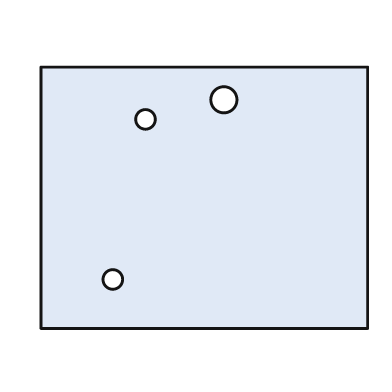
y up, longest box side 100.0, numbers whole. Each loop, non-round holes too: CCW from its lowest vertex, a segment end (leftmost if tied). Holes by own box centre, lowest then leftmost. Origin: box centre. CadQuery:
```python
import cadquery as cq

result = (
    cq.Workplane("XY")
    .moveTo(-50.0, -40.0)
    .lineTo(50.0, -40.0)
    .lineTo(50.0, 40.0)
    .lineTo(-50.0, 40.0)
    .close()
    .moveTo(-28.0, -25.0)
    .circle(3.0)
    .moveTo(-18.0, 24.0)
    .circle(3.0)
    .moveTo(6.0, 30.0)
    .circle(4.0)
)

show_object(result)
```